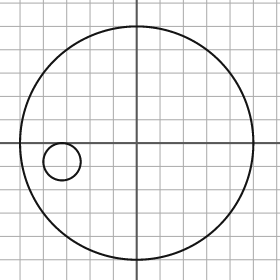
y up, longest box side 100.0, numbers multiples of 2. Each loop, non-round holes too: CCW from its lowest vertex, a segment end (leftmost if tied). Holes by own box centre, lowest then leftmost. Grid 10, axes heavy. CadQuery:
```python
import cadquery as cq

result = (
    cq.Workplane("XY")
    .moveTo(0.0, 0.0)
    .circle(50.0)
    .moveTo(-32.0, -8.0)
    .circle(8.0)
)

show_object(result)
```